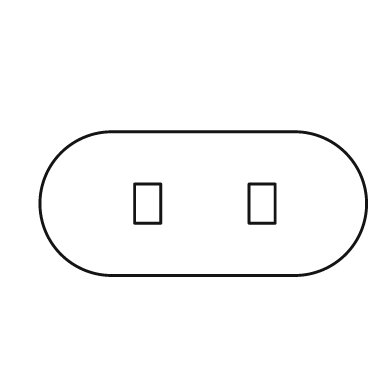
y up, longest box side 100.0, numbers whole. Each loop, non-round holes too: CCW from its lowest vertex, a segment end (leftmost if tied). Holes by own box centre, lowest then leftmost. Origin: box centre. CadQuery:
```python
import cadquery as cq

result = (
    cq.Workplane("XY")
    .moveTo(-28.0, -22.0)
    .lineTo(28.0, -22.0)
    .threePointArc((50.0, 0.0), (28.0, 22.0))
    .lineTo(-28.0, 22.0)
    .threePointArc((-50.0, 0.0), (-28.0, -22.0))
    .close()
    .moveTo(-21.0, -6.0)
    .lineTo(-13.0, -6.0)
    .lineTo(-13.0, 6.0)
    .lineTo(-21.0, 6.0)
    .close()
    .moveTo(14.0, -6.0)
    .lineTo(22.0, -6.0)
    .lineTo(22.0, 6.0)
    .lineTo(14.0, 6.0)
    .close()
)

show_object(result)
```